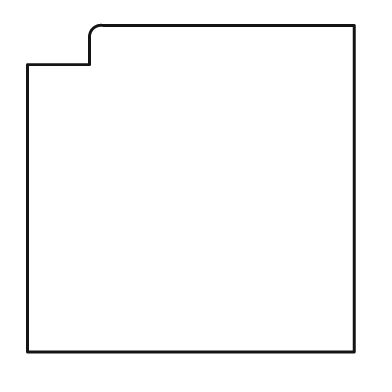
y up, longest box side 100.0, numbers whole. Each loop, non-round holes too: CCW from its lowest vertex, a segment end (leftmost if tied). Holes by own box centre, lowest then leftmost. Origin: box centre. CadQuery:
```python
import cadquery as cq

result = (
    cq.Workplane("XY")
    .moveTo(-50.0, -50.0)
    .lineTo(50.0, -50.0)
    .lineTo(50.0, 50.0)
    .lineTo(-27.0, 50.0)
    .threePointArc((-30.0, 49.0), (-31.0, 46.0))
    .lineTo(-31.0, 38.0)
    .lineTo(-50.0, 38.0)
    .close()
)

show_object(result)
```